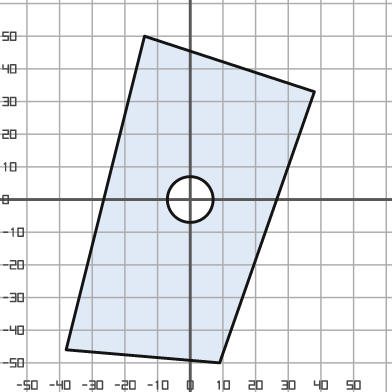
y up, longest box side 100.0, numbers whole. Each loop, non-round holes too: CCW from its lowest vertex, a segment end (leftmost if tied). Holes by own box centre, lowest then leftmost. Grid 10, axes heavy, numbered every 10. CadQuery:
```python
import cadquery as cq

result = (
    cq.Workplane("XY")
    .moveTo(9.0, -50.0)
    .lineTo(38.0, 33.0)
    .lineTo(-14.0, 50.0)
    .lineTo(-38.0, -46.0)
    .close()
    .moveTo(0.0, 0.0)
    .circle(7.0)
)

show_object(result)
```